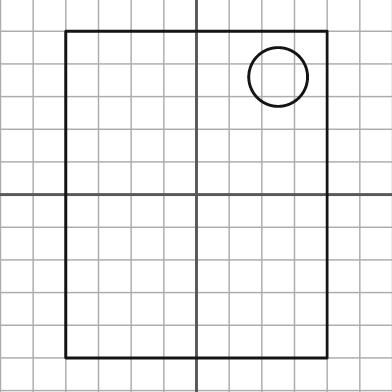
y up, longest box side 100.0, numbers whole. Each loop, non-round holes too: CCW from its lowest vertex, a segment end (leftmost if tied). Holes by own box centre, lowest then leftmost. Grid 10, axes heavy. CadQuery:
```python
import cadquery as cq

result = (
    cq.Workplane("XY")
    .moveTo(-40.0, -50.0)
    .lineTo(40.0, -50.0)
    .lineTo(40.0, 50.0)
    .lineTo(-40.0, 50.0)
    .close()
    .moveTo(25.0, 36.0)
    .circle(9.0)
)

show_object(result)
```